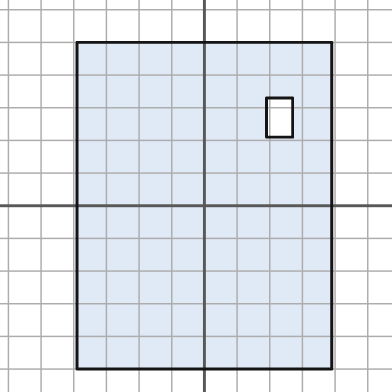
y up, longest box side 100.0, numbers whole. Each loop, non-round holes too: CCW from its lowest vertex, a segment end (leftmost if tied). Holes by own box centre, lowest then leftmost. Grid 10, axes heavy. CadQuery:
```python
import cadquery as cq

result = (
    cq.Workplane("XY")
    .moveTo(-39.0, -50.0)
    .lineTo(39.0, -50.0)
    .lineTo(39.0, 50.0)
    .lineTo(-39.0, 50.0)
    .close()
    .moveTo(19.0, 21.0)
    .lineTo(27.0, 21.0)
    .lineTo(27.0, 33.0)
    .lineTo(19.0, 33.0)
    .close()
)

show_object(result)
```